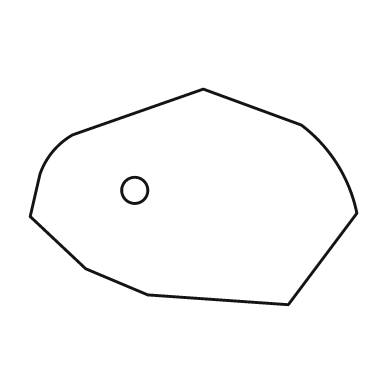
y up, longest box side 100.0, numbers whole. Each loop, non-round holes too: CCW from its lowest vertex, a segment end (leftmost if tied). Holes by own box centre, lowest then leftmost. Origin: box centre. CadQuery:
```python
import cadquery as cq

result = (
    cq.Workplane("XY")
    .moveTo(29.0, -33.0)
    .lineTo(50.0, -5.0)
    .threePointArc((44.0, 10.0), (33.0, 22.0))
    .lineTo(3.0, 33.0)
    .lineTo(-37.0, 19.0)
    .threePointArc((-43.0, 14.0), (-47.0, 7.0))
    .lineTo(-50.0, -6.0)
    .lineTo(-33.0, -22.0)
    .lineTo(-14.0, -30.0)
    .close()
    .moveTo(-18.0, 2.0)
    .circle(4.0)
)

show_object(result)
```